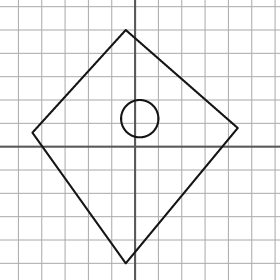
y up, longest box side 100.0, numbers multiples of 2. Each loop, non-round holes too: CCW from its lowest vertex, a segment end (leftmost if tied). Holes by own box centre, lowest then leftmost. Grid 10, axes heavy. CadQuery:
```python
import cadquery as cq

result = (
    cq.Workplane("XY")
    .moveTo(-4.0, -50.0)
    .lineTo(44.0, 8.0)
    .lineTo(-4.0, 50.0)
    .lineTo(-44.0, 6.0)
    .close()
    .moveTo(2.0, 12.0)
    .circle(8.0)
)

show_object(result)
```